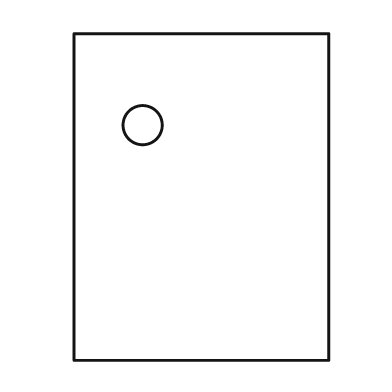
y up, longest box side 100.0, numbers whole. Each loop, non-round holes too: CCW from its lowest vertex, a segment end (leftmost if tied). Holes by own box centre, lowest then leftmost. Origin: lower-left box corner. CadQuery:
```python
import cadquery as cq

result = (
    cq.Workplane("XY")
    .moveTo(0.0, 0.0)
    .lineTo(78.0, 0.0)
    .lineTo(78.0, 100.0)
    .lineTo(0.0, 100.0)
    .close()
    .moveTo(21.0, 72.0)
    .circle(6.0)
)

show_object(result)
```